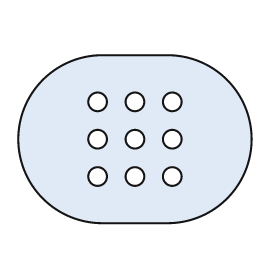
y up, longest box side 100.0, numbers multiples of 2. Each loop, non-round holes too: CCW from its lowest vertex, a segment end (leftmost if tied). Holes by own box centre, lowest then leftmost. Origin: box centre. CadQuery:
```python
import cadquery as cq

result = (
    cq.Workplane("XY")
    .moveTo(-14.0, -36.0)
    .lineTo(14.0, -36.0)
    .threePointArc((50.0, 0.0), (14.0, 36.0))
    .lineTo(-14.0, 36.0)
    .threePointArc((-50.0, 0.0), (-14.0, -36.0))
    .close()
    .moveTo(-16.0, -16.0)
    .circle(4.0)
    .moveTo(0.0, -16.0)
    .circle(4.0)
    .moveTo(16.0, -16.0)
    .circle(4.0)
    .moveTo(-16.0, 0.0)
    .circle(4.0)
    .moveTo(0.0, 0.0)
    .circle(4.0)
    .moveTo(16.0, 0.0)
    .circle(4.0)
    .moveTo(-16.0, 16.0)
    .circle(4.0)
    .moveTo(0.0, 16.0)
    .circle(4.0)
    .moveTo(16.0, 16.0)
    .circle(4.0)
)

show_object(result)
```